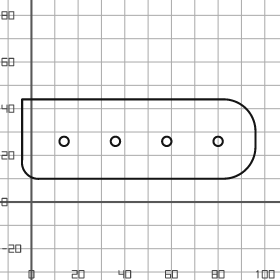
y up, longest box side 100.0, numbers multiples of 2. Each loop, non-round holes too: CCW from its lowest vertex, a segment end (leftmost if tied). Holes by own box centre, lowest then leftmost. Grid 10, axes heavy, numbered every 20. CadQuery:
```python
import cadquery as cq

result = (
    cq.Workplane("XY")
    .moveTo(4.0, 10.0)
    .lineTo(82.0, 10.0)
    .threePointArc((92.0, 14.0), (96.0, 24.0))
    .lineTo(96.0, 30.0)
    .threePointArc((92.0, 40.0), (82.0, 44.0))
    .lineTo(-4.0, 44.0)
    .lineTo(-4.0, 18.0)
    .threePointArc((-2.0, 12.0), (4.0, 10.0))
    .close()
    .moveTo(14.0, 26.0)
    .circle(2.0)
    .moveTo(36.0, 26.0)
    .circle(2.0)
    .moveTo(58.0, 26.0)
    .circle(2.0)
    .moveTo(80.0, 26.0)
    .circle(2.0)
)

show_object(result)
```